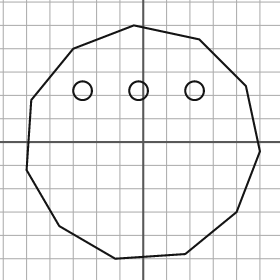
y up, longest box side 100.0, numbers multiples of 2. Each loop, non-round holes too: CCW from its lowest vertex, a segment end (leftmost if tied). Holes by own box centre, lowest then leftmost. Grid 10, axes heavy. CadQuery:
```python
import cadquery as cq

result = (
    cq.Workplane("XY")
    .moveTo(-12.0, -50.0)
    .lineTo(18.0, -48.0)
    .lineTo(40.0, -30.0)
    .lineTo(50.0, -4.0)
    .lineTo(44.0, 24.0)
    .lineTo(24.0, 44.0)
    .lineTo(-4.0, 50.0)
    .lineTo(-30.0, 40.0)
    .lineTo(-48.0, 18.0)
    .lineTo(-50.0, -12.0)
    .lineTo(-36.0, -36.0)
    .close()
    .moveTo(-26.0, 22.0)
    .circle(4.0)
    .moveTo(-2.0, 22.0)
    .circle(4.0)
    .moveTo(22.0, 22.0)
    .circle(4.0)
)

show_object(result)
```